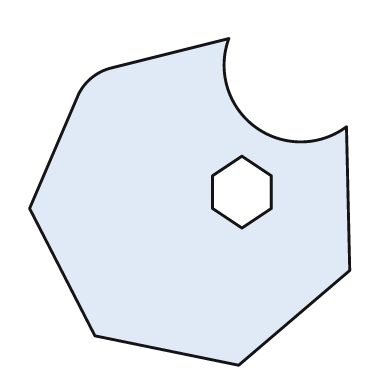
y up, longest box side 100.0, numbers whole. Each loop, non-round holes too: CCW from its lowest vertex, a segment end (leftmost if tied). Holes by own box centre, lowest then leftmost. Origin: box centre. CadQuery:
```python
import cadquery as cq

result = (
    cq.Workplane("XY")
    .moveTo(15.0, -50.0)
    .lineTo(49.0, -21.0)
    .lineTo(48.0, 23.0)
    .threePointArc((20.0, 23.0), (12.0, 50.0))
    .lineTo(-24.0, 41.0)
    .threePointArc((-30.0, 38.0), (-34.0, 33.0))
    .lineTo(-49.0, -2.0)
    .lineTo(-29.0, -41.0)
    .close()
    .moveTo(16.0, -8.0)
    .lineTo(25.0, -2.0)
    .lineTo(25.0, 8.0)
    .lineTo(16.0, 14.0)
    .lineTo(7.0, 8.0)
    .lineTo(7.0, -2.0)
    .close()
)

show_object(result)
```